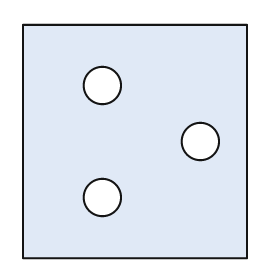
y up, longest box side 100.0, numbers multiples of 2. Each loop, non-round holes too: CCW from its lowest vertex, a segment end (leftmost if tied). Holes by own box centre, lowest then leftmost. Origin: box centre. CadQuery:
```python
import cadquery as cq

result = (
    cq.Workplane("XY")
    .moveTo(-48.0, -50.0)
    .lineTo(48.0, -50.0)
    .lineTo(48.0, 50.0)
    .lineTo(-48.0, 50.0)
    .close()
    .moveTo(-14.0, -24.0)
    .circle(8.0)
    .moveTo(28.0, 0.0)
    .circle(8.0)
    .moveTo(-14.0, 24.0)
    .circle(8.0)
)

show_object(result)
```